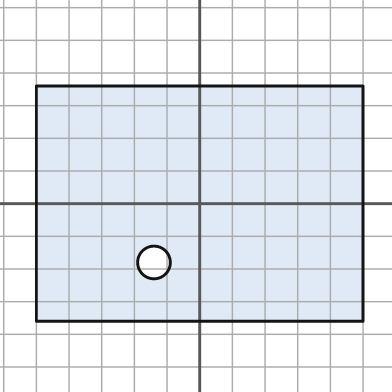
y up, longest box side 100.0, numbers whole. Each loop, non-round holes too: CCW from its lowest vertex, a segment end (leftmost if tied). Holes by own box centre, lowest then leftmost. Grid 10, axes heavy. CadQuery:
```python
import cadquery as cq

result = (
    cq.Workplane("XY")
    .moveTo(-50.0, -36.0)
    .lineTo(50.0, -36.0)
    .lineTo(50.0, 36.0)
    .lineTo(-50.0, 36.0)
    .close()
    .moveTo(-14.0, -18.0)
    .circle(5.0)
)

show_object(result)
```